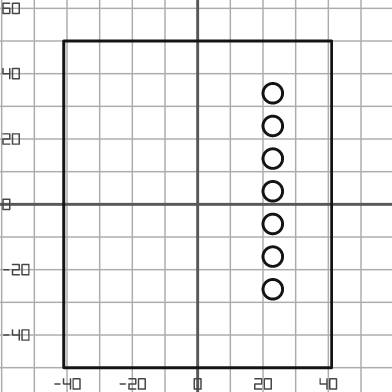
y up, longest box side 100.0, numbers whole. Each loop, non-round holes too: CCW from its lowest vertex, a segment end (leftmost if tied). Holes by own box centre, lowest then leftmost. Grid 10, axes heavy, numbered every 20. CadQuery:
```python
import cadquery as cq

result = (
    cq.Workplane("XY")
    .moveTo(-41.0, -50.0)
    .lineTo(41.0, -50.0)
    .lineTo(41.0, 50.0)
    .lineTo(-41.0, 50.0)
    .close()
    .moveTo(23.0, -26.0)
    .circle(3.0)
    .moveTo(23.0, -16.0)
    .circle(3.0)
    .moveTo(23.0, -6.0)
    .circle(3.0)
    .moveTo(23.0, 4.0)
    .circle(3.0)
    .moveTo(23.0, 14.0)
    .circle(3.0)
    .moveTo(23.0, 24.0)
    .circle(3.0)
    .moveTo(23.0, 34.0)
    .circle(3.0)
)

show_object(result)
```